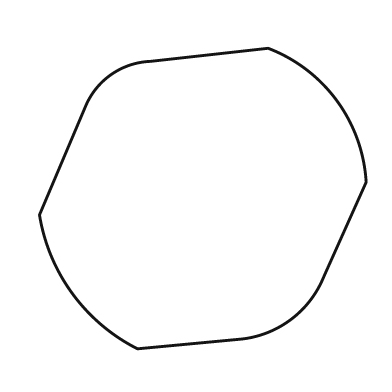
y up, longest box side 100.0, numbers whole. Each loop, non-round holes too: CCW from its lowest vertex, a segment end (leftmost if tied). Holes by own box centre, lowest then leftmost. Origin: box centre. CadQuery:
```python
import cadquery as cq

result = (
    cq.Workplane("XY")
    .moveTo(-20.0, -46.0)
    .lineTo(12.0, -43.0)
    .threePointArc((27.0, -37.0), (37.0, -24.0))
    .lineTo(50.0, 5.0)
    .threePointArc((41.0, 30.0), (20.0, 46.0))
    .lineTo(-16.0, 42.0)
    .threePointArc((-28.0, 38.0), (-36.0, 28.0))
    .lineTo(-50.0, -5.0)
    .threePointArc((-40.0, -29.0), (-20.0, -46.0))
    .close()
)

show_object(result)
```